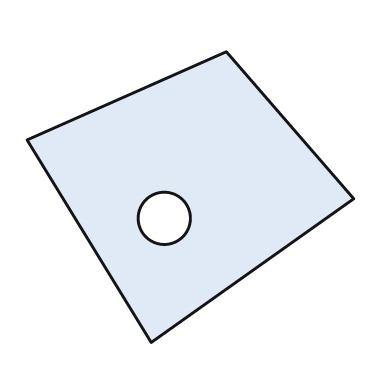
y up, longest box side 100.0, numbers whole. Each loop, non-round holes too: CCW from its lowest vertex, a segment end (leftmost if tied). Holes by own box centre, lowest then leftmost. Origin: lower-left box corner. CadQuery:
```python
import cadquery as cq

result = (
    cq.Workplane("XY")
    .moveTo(38.0, 0.0)
    .lineTo(100.0, 44.0)
    .lineTo(61.0, 89.0)
    .lineTo(0.0, 62.0)
    .close()
    .moveTo(42.0, 38.0)
    .circle(8.0)
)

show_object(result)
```